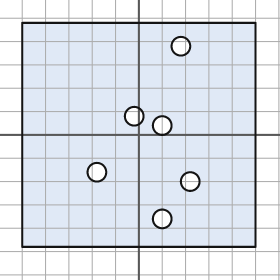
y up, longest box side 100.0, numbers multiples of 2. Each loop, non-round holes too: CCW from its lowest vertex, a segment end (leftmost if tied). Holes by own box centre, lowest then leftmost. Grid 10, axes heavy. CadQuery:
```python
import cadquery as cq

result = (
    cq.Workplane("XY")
    .moveTo(-50.0, -48.0)
    .lineTo(50.0, -48.0)
    .lineTo(50.0, 48.0)
    .lineTo(-50.0, 48.0)
    .close()
    .moveTo(10.0, -36.0)
    .circle(4.0)
    .moveTo(22.0, -20.0)
    .circle(4.0)
    .moveTo(-18.0, -16.0)
    .circle(4.0)
    .moveTo(10.0, 4.0)
    .circle(4.0)
    .moveTo(-2.0, 8.0)
    .circle(4.0)
    .moveTo(18.0, 38.0)
    .circle(4.0)
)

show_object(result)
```